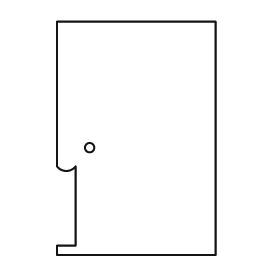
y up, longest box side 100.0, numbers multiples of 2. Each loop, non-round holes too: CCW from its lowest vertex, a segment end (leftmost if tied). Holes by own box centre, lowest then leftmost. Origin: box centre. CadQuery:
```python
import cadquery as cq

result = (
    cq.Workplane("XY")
    .moveTo(-34.0, -50.0)
    .lineTo(34.0, -50.0)
    .lineTo(34.0, 50.0)
    .lineTo(-34.0, 50.0)
    .lineTo(-34.0, -12.0)
    .threePointArc((-30.0, -14.0), (-26.0, -12.0))
    .lineTo(-26.0, -46.0)
    .lineTo(-34.0, -46.0)
    .close()
    .moveTo(-20.0, -4.0)
    .circle(2.0)
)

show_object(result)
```